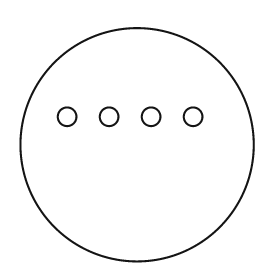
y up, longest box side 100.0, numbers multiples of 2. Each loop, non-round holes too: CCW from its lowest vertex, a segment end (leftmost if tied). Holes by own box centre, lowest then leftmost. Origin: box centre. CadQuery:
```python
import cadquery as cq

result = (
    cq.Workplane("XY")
    .moveTo(0.0, 0.0)
    .circle(50.0)
    .moveTo(-30.0, 12.0)
    .circle(4.0)
    .moveTo(-12.0, 12.0)
    .circle(4.0)
    .moveTo(6.0, 12.0)
    .circle(4.0)
    .moveTo(24.0, 12.0)
    .circle(4.0)
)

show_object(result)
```